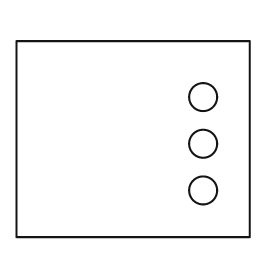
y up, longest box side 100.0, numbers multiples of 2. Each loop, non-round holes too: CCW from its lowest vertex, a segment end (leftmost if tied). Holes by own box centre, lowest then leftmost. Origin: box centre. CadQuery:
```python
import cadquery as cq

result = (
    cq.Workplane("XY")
    .moveTo(-50.0, -42.0)
    .lineTo(50.0, -42.0)
    .lineTo(50.0, 42.0)
    .lineTo(-50.0, 42.0)
    .close()
    .moveTo(30.0, -22.0)
    .circle(6.0)
    .moveTo(30.0, -2.0)
    .circle(6.0)
    .moveTo(30.0, 18.0)
    .circle(6.0)
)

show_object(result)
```